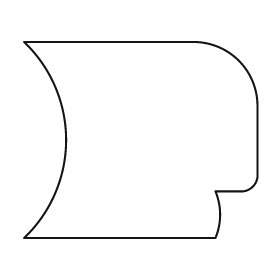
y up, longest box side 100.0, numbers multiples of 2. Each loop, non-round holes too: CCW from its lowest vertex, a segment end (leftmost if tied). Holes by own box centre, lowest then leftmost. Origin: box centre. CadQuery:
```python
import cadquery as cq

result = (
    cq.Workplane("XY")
    .moveTo(-50.0, -42.0)
    .lineTo(32.0, -42.0)
    .threePointArc((34.0, -32.0), (32.0, -22.0))
    .lineTo(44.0, -22.0)
    .threePointArc((48.0, -20.0), (50.0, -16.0))
    .lineTo(50.0, 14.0)
    .threePointArc((42.0, 34.0), (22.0, 42.0))
    .lineTo(-50.0, 42.0)
    .threePointArc((-32.0, 0.0), (-50.0, -42.0))
    .close()
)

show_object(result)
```